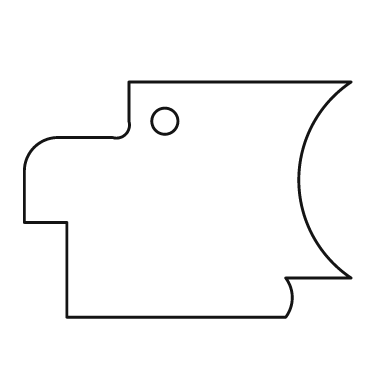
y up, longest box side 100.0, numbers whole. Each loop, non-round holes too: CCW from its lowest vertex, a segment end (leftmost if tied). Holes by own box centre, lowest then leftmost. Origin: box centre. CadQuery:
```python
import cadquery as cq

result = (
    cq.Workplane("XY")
    .moveTo(-37.0, -36.0)
    .lineTo(30.0, -36.0)
    .threePointArc((32.0, -30.0), (30.0, -24.0))
    .lineTo(50.0, -24.0)
    .threePointArc((34.0, 6.0), (50.0, 36.0))
    .lineTo(-18.0, 36.0)
    .lineTo(-18.0, 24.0)
    .threePointArc((-19.0, 20.0), (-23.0, 19.0))
    .lineTo(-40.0, 19.0)
    .threePointArc((-47.0, 16.0), (-50.0, 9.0))
    .lineTo(-50.0, -7.0)
    .lineTo(-37.0, -7.0)
    .close()
    .moveTo(-7.0, 24.0)
    .circle(4.0)
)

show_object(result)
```